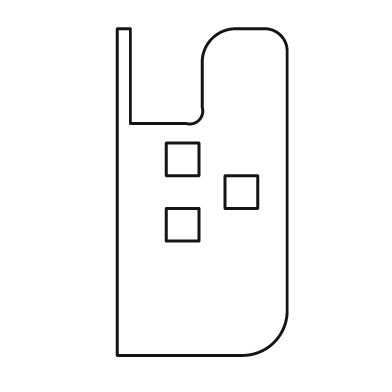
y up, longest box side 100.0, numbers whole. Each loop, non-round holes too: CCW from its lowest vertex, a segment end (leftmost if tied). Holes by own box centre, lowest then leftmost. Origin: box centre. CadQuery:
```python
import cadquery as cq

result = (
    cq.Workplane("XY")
    .moveTo(-26.0, -50.0)
    .lineTo(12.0, -50.0)
    .threePointArc((22.0, -46.0), (26.0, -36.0))
    .lineTo(26.0, 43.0)
    .threePointArc((24.0, 48.0), (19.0, 50.0))
    .lineTo(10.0, 50.0)
    .threePointArc((3.0, 47.0), (0.0, 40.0))
    .lineTo(0.0, 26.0)
    .threePointArc((-1.0, 22.0), (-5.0, 21.0))
    .lineTo(-22.0, 21.0)
    .lineTo(-22.0, 50.0)
    .lineTo(-26.0, 50.0)
    .close()
    .moveTo(-11.0, -15.0)
    .lineTo(-1.0, -15.0)
    .lineTo(-1.0, -5.0)
    .lineTo(-11.0, -5.0)
    .close()
    .moveTo(7.0, -5.0)
    .lineTo(17.0, -5.0)
    .lineTo(17.0, 5.0)
    .lineTo(7.0, 5.0)
    .close()
    .moveTo(-11.0, 5.0)
    .lineTo(-1.0, 5.0)
    .lineTo(-1.0, 15.0)
    .lineTo(-11.0, 15.0)
    .close()
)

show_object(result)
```